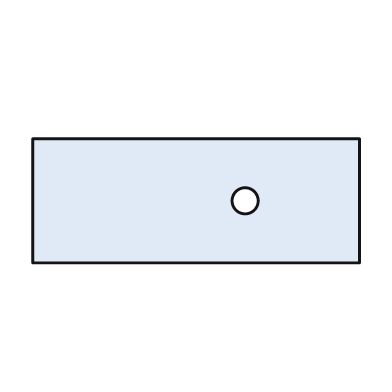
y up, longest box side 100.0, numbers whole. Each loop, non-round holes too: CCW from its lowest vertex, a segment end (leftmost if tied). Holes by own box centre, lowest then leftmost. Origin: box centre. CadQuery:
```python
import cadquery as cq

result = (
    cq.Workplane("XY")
    .moveTo(-50.0, -19.0)
    .lineTo(50.0, -19.0)
    .lineTo(50.0, 19.0)
    .lineTo(-50.0, 19.0)
    .close()
    .moveTo(15.0, 0.0)
    .circle(4.0)
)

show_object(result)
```